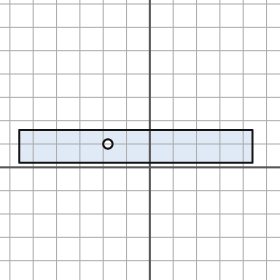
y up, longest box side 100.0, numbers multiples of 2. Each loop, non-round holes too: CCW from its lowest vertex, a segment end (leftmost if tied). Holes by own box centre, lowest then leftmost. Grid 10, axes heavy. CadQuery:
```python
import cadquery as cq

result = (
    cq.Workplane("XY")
    .moveTo(-56.0, 2.0)
    .lineTo(44.0, 2.0)
    .lineTo(44.0, 16.0)
    .lineTo(-56.0, 16.0)
    .close()
    .moveTo(-18.0, 10.0)
    .circle(2.0)
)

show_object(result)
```